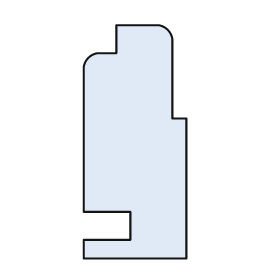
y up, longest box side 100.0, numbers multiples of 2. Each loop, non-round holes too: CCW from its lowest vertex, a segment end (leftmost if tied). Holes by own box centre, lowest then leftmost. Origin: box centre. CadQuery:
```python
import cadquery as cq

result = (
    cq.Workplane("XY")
    .moveTo(-22.0, -50.0)
    .lineTo(22.0, -50.0)
    .lineTo(22.0, 10.0)
    .lineTo(16.0, 10.0)
    .lineTo(16.0, 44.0)
    .threePointArc((14.0, 48.0), (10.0, 50.0))
    .lineTo(-8.0, 50.0)
    .lineTo(-8.0, 38.0)
    .lineTo(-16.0, 38.0)
    .threePointArc((-20.0, 36.0), (-22.0, 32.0))
    .lineTo(-22.0, -30.0)
    .lineTo(-2.0, -30.0)
    .lineTo(-2.0, -42.0)
    .lineTo(-22.0, -42.0)
    .close()
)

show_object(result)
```